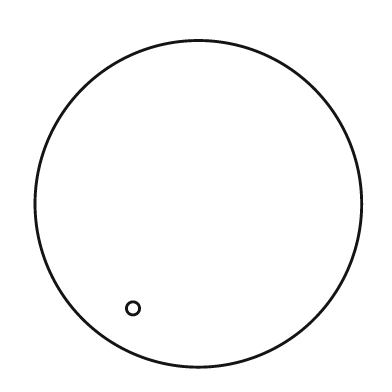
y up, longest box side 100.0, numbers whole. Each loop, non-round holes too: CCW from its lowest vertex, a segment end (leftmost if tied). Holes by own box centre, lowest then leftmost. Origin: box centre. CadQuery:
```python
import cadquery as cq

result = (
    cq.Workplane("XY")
    .moveTo(0.0, 0.0)
    .circle(50.0)
    .moveTo(-20.0, -32.0)
    .circle(2.0)
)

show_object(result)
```